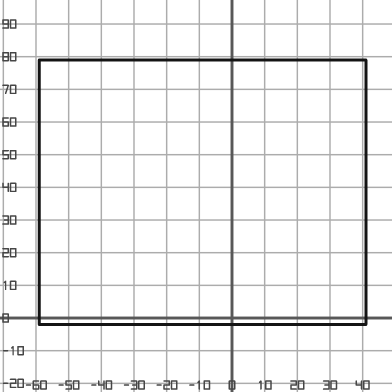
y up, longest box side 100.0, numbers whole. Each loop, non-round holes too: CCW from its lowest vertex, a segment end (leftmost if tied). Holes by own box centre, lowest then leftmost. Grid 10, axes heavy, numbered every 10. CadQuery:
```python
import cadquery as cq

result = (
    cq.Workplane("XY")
    .moveTo(-59.0, -2.0)
    .lineTo(41.0, -2.0)
    .lineTo(41.0, 79.0)
    .lineTo(-59.0, 79.0)
    .close()
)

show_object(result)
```